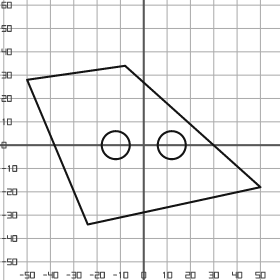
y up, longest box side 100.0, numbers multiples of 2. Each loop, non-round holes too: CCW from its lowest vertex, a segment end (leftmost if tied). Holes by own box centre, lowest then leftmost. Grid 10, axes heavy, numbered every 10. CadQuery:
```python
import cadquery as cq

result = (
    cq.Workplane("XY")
    .moveTo(-24.0, -34.0)
    .lineTo(50.0, -18.0)
    .lineTo(-8.0, 34.0)
    .lineTo(-50.0, 28.0)
    .close()
    .moveTo(-12.0, 0.0)
    .circle(6.0)
    .moveTo(12.0, 0.0)
    .circle(6.0)
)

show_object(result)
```